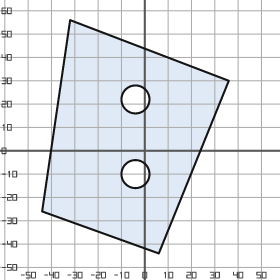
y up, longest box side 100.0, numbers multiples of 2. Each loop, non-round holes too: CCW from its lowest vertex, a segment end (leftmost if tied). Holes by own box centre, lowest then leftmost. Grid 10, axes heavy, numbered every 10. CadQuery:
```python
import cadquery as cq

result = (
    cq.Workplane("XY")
    .moveTo(6.0, -44.0)
    .lineTo(36.0, 30.0)
    .lineTo(-32.0, 56.0)
    .lineTo(-44.0, -26.0)
    .close()
    .moveTo(-4.0, -10.0)
    .circle(6.0)
    .moveTo(-4.0, 22.0)
    .circle(6.0)
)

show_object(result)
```